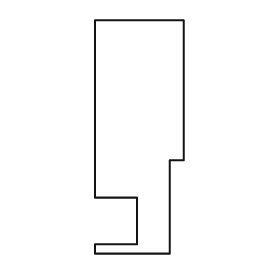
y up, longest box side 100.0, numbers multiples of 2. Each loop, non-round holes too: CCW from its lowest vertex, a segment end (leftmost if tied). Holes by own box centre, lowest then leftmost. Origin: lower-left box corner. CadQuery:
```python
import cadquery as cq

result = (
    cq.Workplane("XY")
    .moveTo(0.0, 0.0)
    .lineTo(32.0, 0.0)
    .lineTo(32.0, 40.0)
    .lineTo(38.0, 40.0)
    .lineTo(38.0, 100.0)
    .lineTo(0.0, 100.0)
    .lineTo(0.0, 24.0)
    .lineTo(18.0, 24.0)
    .lineTo(18.0, 4.0)
    .lineTo(0.0, 4.0)
    .close()
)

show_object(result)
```